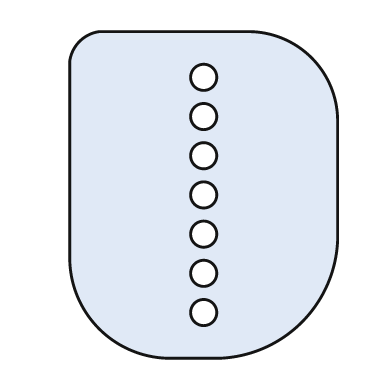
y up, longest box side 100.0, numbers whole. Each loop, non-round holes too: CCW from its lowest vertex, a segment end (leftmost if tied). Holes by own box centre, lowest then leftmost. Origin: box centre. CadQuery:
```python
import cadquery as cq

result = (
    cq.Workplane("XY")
    .moveTo(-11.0, -50.0)
    .lineTo(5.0, -50.0)
    .threePointArc((30.0, -39.0), (41.0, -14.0))
    .lineTo(41.0, 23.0)
    .threePointArc((33.0, 42.0), (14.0, 50.0))
    .lineTo(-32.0, 50.0)
    .threePointArc((-38.0, 47.0), (-41.0, 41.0))
    .lineTo(-41.0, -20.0)
    .threePointArc((-32.0, -41.0), (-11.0, -50.0))
    .close()
    .moveTo(0.0, -36.0)
    .circle(4.0)
    .moveTo(0.0, -24.0)
    .circle(4.0)
    .moveTo(0.0, -12.0)
    .circle(4.0)
    .moveTo(0.0, 0.0)
    .circle(4.0)
    .moveTo(0.0, 12.0)
    .circle(4.0)
    .moveTo(0.0, 24.0)
    .circle(4.0)
    .moveTo(0.0, 36.0)
    .circle(4.0)
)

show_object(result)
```